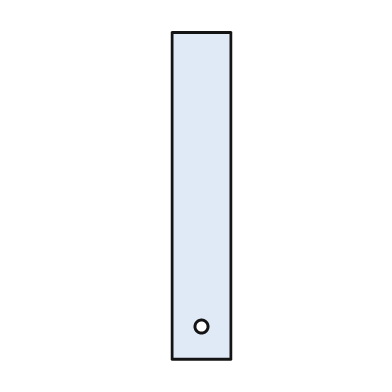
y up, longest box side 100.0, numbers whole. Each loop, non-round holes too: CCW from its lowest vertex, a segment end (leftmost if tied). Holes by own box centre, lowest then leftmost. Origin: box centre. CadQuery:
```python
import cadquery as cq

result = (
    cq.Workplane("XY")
    .moveTo(-9.0, -50.0)
    .lineTo(9.0, -50.0)
    .lineTo(9.0, 50.0)
    .lineTo(-9.0, 50.0)
    .close()
    .moveTo(0.0, -40.0)
    .circle(2.0)
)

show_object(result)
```